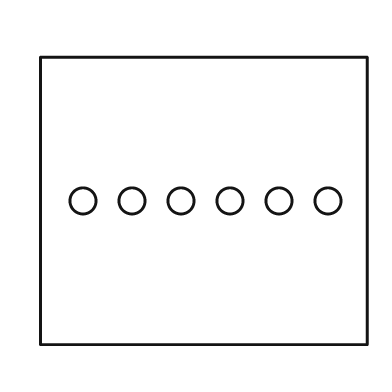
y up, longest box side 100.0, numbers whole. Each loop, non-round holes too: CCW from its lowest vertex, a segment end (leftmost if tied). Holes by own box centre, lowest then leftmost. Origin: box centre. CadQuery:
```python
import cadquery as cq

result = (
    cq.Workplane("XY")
    .moveTo(-50.0, -44.0)
    .lineTo(50.0, -44.0)
    .lineTo(50.0, 44.0)
    .lineTo(-50.0, 44.0)
    .close()
    .moveTo(-37.0, 0.0)
    .circle(4.0)
    .moveTo(-22.0, 0.0)
    .circle(4.0)
    .moveTo(-7.0, 0.0)
    .circle(4.0)
    .moveTo(8.0, 0.0)
    .circle(4.0)
    .moveTo(23.0, 0.0)
    .circle(4.0)
    .moveTo(38.0, 0.0)
    .circle(4.0)
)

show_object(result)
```